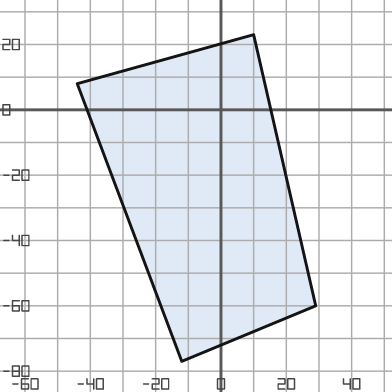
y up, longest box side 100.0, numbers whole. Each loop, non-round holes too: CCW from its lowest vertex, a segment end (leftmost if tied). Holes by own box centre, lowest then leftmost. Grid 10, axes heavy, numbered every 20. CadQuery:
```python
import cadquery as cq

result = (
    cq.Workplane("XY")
    .moveTo(-12.0, -77.0)
    .lineTo(29.0, -60.0)
    .lineTo(10.0, 23.0)
    .lineTo(-44.0, 8.0)
    .close()
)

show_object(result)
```